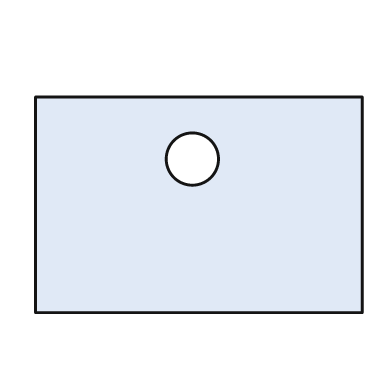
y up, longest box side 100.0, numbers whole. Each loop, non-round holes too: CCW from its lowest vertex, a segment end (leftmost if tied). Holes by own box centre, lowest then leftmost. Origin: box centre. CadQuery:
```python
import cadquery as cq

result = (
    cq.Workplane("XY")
    .moveTo(-50.0, -33.0)
    .lineTo(50.0, -33.0)
    .lineTo(50.0, 33.0)
    .lineTo(-50.0, 33.0)
    .close()
    .moveTo(-2.0, 14.0)
    .circle(8.0)
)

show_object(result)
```